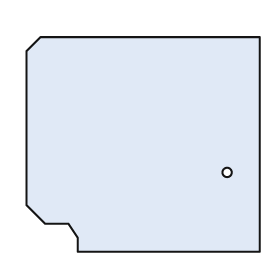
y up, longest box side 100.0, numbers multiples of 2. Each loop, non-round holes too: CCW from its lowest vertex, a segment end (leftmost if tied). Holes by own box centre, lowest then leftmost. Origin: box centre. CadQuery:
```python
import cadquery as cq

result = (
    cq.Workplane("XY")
    .moveTo(-28.0, -46.0)
    .lineTo(50.0, -46.0)
    .lineTo(50.0, 46.0)
    .lineTo(-44.0, 46.0)
    .lineTo(-50.0, 40.0)
    .lineTo(-50.0, -26.0)
    .lineTo(-42.0, -34.0)
    .lineTo(-32.0, -34.0)
    .lineTo(-28.0, -40.0)
    .close()
    .moveTo(36.0, -12.0)
    .circle(2.0)
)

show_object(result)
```